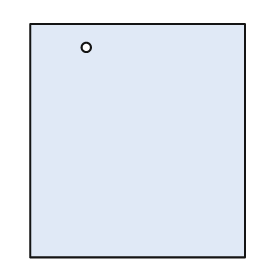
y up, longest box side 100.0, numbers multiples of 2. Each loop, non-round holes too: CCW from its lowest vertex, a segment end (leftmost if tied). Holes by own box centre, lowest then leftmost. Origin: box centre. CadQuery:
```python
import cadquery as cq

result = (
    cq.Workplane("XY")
    .moveTo(-46.0, -50.0)
    .lineTo(46.0, -50.0)
    .lineTo(46.0, 50.0)
    .lineTo(-46.0, 50.0)
    .close()
    .moveTo(-22.0, 40.0)
    .circle(2.0)
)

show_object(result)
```